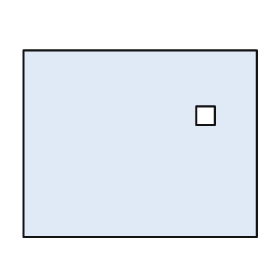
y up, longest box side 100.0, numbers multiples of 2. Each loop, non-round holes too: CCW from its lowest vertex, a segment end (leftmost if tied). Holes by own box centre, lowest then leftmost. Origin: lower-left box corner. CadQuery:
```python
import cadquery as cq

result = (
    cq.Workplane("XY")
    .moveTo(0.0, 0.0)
    .lineTo(100.0, 0.0)
    .lineTo(100.0, 80.0)
    .lineTo(0.0, 80.0)
    .close()
    .moveTo(74.0, 48.0)
    .lineTo(82.0, 48.0)
    .lineTo(82.0, 56.0)
    .lineTo(74.0, 56.0)
    .close()
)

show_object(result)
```